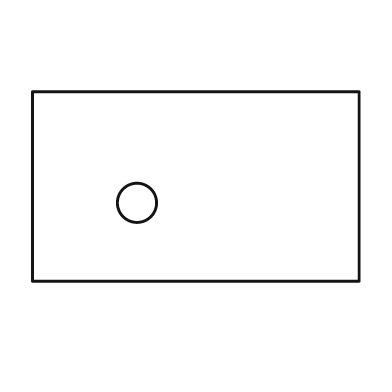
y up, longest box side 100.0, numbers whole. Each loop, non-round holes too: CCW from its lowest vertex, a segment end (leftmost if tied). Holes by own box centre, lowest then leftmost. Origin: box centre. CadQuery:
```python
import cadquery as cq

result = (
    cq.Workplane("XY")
    .moveTo(-50.0, -29.0)
    .lineTo(50.0, -29.0)
    .lineTo(50.0, 29.0)
    .lineTo(-50.0, 29.0)
    .close()
    .moveTo(-18.0, -5.0)
    .circle(6.0)
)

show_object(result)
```